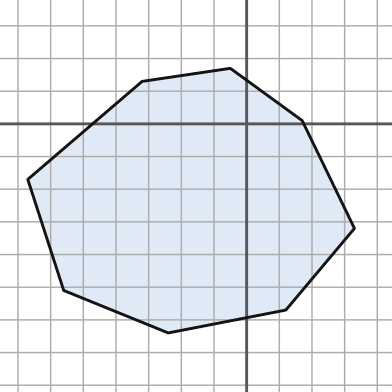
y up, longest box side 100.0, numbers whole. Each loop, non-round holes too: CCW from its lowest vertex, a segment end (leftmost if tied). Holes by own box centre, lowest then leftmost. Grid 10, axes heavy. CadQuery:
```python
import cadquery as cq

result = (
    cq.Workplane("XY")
    .moveTo(-24.0, -64.0)
    .lineTo(12.0, -57.0)
    .lineTo(33.0, -32.0)
    .lineTo(17.0, 1.0)
    .lineTo(-5.0, 17.0)
    .lineTo(-32.0, 13.0)
    .lineTo(-67.0, -17.0)
    .lineTo(-56.0, -51.0)
    .close()
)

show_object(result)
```